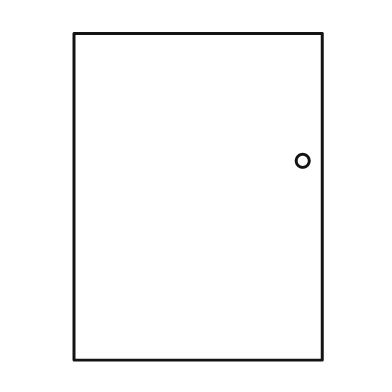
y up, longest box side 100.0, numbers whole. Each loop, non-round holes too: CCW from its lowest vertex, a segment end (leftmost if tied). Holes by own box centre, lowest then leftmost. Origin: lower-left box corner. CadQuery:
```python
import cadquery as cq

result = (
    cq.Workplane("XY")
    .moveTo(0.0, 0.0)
    .lineTo(76.0, 0.0)
    .lineTo(76.0, 100.0)
    .lineTo(0.0, 100.0)
    .close()
    .moveTo(70.0, 61.0)
    .circle(2.0)
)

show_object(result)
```